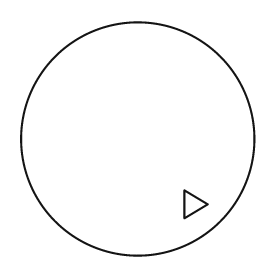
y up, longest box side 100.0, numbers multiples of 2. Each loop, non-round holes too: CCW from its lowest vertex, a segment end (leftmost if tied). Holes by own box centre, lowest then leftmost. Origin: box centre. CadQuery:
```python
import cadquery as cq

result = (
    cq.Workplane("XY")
    .moveTo(0.0, 0.0)
    .circle(50.0)
    .moveTo(20.0, -34.0)
    .lineTo(30.0, -28.0)
    .lineTo(20.0, -22.0)
    .close()
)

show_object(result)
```